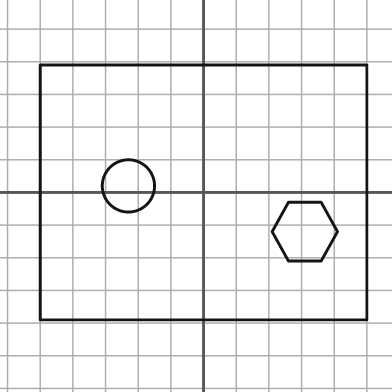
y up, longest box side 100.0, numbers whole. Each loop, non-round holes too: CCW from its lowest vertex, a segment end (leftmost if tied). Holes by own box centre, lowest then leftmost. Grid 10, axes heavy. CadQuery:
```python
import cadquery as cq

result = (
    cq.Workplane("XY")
    .moveTo(-50.0, -39.0)
    .lineTo(50.0, -39.0)
    .lineTo(50.0, 39.0)
    .lineTo(-50.0, 39.0)
    .close()
    .moveTo(26.0, -21.0)
    .lineTo(36.0, -21.0)
    .lineTo(41.0, -12.0)
    .lineTo(36.0, -3.0)
    .lineTo(26.0, -3.0)
    .lineTo(21.0, -12.0)
    .close()
    .moveTo(-23.0, 2.0)
    .circle(8.0)
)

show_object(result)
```